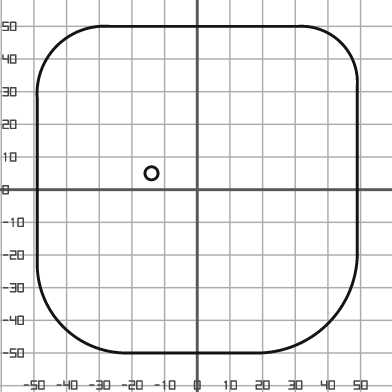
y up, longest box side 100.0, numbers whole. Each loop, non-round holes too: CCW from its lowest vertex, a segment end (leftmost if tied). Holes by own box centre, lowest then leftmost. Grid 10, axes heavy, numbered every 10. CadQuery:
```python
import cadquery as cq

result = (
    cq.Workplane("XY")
    .moveTo(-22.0, -50.0)
    .lineTo(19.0, -50.0)
    .threePointArc((40.0, -41.0), (49.0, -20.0))
    .lineTo(49.0, 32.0)
    .threePointArc((44.0, 45.0), (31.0, 50.0))
    .lineTo(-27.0, 50.0)
    .threePointArc((-43.0, 44.0), (-49.0, 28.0))
    .lineTo(-49.0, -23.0)
    .threePointArc((-41.0, -42.0), (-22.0, -50.0))
    .close()
    .moveTo(-14.0, 5.0)
    .circle(2.0)
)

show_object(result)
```